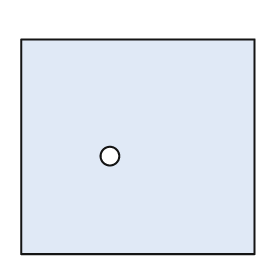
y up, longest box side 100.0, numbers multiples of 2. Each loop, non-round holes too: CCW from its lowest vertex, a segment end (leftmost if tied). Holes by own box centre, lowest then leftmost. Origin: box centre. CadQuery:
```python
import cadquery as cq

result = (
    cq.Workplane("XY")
    .moveTo(-50.0, -46.0)
    .lineTo(50.0, -46.0)
    .lineTo(50.0, 46.0)
    .lineTo(-50.0, 46.0)
    .close()
    .moveTo(-12.0, -4.0)
    .circle(4.0)
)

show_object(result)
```